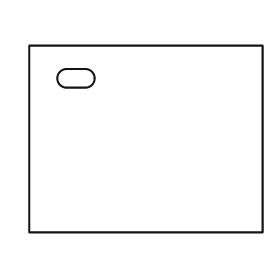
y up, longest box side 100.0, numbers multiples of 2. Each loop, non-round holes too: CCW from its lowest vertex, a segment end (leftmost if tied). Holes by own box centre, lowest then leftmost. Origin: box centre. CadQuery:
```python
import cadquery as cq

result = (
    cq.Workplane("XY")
    .moveTo(-50.0, -40.0)
    .lineTo(50.0, -40.0)
    .lineTo(50.0, 40.0)
    .lineTo(-50.0, 40.0)
    .close()
    .moveTo(-34.0, 22.0)
    .lineTo(-26.0, 22.0)
    .threePointArc((-22.0, 26.0), (-26.0, 30.0))
    .lineTo(-34.0, 30.0)
    .threePointArc((-38.0, 26.0), (-34.0, 22.0))
    .close()
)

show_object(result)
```